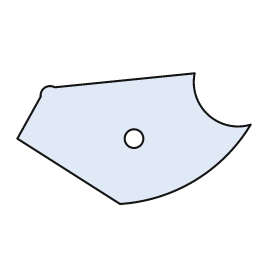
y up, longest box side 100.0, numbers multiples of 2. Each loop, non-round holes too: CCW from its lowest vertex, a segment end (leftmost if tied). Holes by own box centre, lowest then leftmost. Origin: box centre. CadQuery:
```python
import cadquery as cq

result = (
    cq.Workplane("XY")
    .moveTo(-6.0, -28.0)
    .threePointArc((26.0, -18.0), (50.0, 6.0))
    .threePointArc((32.0, 10.0), (26.0, 28.0))
    .lineTo(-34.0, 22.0)
    .threePointArc((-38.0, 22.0), (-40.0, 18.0))
    .lineTo(-50.0, 0.0)
    .close()
    .moveTo(0.0, 0.0)
    .circle(4.0)
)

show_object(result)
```